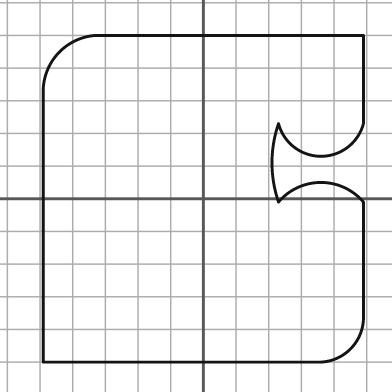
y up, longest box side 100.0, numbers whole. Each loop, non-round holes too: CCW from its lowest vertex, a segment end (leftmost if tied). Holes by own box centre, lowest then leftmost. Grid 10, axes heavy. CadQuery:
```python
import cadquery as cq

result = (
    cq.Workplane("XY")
    .moveTo(-49.0, -50.0)
    .lineTo(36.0, -50.0)
    .threePointArc((45.0, -46.0), (49.0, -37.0))
    .lineTo(49.0, -1.0)
    .threePointArc((36.0, 5.0), (23.0, -1.0))
    .threePointArc((21.0, 11.0), (23.0, 23.0))
    .threePointArc((36.0, 13.0), (49.0, 23.0))
    .lineTo(49.0, 50.0)
    .lineTo(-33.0, 50.0)
    .threePointArc((-44.0, 45.0), (-49.0, 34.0))
    .close()
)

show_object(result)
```